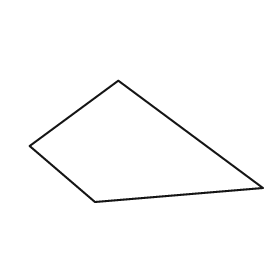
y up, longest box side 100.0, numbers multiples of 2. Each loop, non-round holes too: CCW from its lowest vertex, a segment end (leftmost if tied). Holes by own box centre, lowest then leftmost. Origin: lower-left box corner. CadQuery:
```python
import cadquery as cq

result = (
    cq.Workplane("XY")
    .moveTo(28.0, 0.0)
    .lineTo(100.0, 6.0)
    .lineTo(38.0, 52.0)
    .lineTo(0.0, 24.0)
    .close()
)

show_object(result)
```